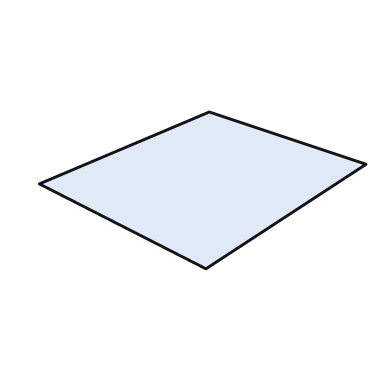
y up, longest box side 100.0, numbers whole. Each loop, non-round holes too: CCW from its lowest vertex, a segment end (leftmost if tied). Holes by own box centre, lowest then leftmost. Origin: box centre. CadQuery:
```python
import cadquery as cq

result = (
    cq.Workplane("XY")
    .moveTo(1.0, -24.0)
    .lineTo(50.0, 8.0)
    .lineTo(2.0, 24.0)
    .lineTo(-50.0, 2.0)
    .close()
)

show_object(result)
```